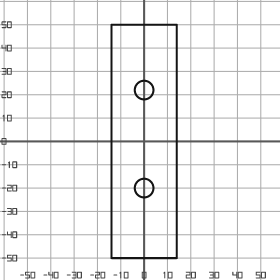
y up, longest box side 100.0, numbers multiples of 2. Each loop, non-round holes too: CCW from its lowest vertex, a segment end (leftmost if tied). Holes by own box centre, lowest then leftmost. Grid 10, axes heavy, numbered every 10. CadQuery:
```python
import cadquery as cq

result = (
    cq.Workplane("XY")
    .moveTo(-14.0, -50.0)
    .lineTo(14.0, -50.0)
    .lineTo(14.0, 50.0)
    .lineTo(-14.0, 50.0)
    .close()
    .moveTo(0.0, -20.0)
    .circle(4.0)
    .moveTo(0.0, 22.0)
    .circle(4.0)
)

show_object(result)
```